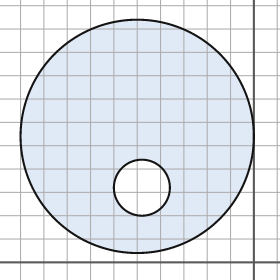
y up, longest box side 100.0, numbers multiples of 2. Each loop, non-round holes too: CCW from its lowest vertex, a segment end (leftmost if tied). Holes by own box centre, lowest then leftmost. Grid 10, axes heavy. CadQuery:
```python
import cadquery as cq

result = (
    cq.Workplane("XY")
    .moveTo(-50.0, 54.0)
    .circle(50.0)
    .moveTo(-48.0, 32.0)
    .circle(12.0)
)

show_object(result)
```